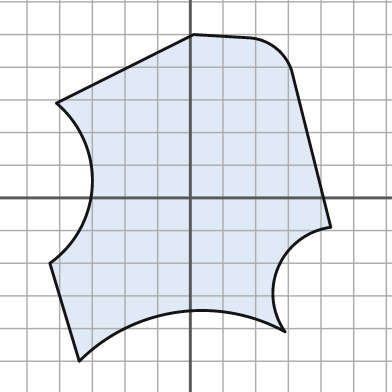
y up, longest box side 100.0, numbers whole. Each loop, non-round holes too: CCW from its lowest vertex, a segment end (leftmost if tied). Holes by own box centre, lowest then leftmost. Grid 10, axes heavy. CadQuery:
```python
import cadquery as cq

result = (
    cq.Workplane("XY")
    .moveTo(-34.0, -50.0)
    .threePointArc((-4.0, -35.0), (29.0, -41.0))
    .threePointArc((27.0, -21.0), (43.0, -9.0))
    .lineTo(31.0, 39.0)
    .threePointArc((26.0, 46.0), (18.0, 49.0))
    .lineTo(1.0, 50.0)
    .lineTo(-41.0, 29.0)
    .threePointArc((-30.0, 4.0), (-43.0, -20.0))
    .close()
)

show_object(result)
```